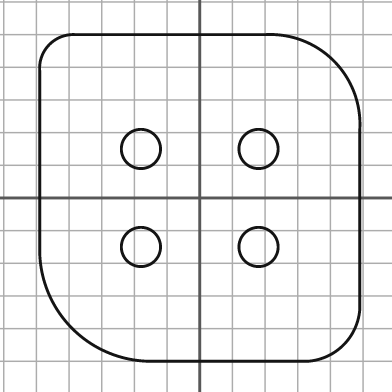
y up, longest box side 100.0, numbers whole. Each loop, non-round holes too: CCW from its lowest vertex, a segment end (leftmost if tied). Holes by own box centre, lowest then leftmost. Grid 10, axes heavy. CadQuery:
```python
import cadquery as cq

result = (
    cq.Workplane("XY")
    .moveTo(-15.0, -50.0)
    .lineTo(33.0, -50.0)
    .threePointArc((44.0, -45.0), (49.0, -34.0))
    .lineTo(49.0, 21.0)
    .threePointArc((41.0, 42.0), (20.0, 50.0))
    .lineTo(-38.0, 50.0)
    .threePointArc((-46.0, 47.0), (-49.0, 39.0))
    .lineTo(-49.0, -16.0)
    .threePointArc((-39.0, -40.0), (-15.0, -50.0))
    .close()
    .moveTo(-18.0, -15.0)
    .circle(6.0)
    .moveTo(18.0, -15.0)
    .circle(6.0)
    .moveTo(-18.0, 15.0)
    .circle(6.0)
    .moveTo(18.0, 15.0)
    .circle(6.0)
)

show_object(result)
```